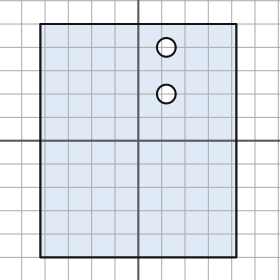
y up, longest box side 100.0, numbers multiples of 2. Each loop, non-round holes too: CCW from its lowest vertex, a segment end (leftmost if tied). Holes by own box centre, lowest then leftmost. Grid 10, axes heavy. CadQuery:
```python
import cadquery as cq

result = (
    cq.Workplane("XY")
    .moveTo(-42.0, -50.0)
    .lineTo(42.0, -50.0)
    .lineTo(42.0, 50.0)
    .lineTo(-42.0, 50.0)
    .close()
    .moveTo(12.0, 20.0)
    .circle(4.0)
    .moveTo(12.0, 40.0)
    .circle(4.0)
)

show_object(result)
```